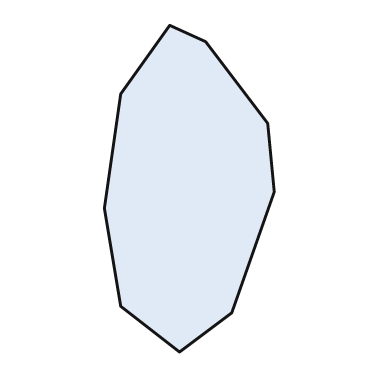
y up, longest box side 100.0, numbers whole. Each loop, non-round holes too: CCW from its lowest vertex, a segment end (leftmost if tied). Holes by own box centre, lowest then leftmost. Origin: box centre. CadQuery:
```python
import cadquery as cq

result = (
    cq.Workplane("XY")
    .moveTo(-3.0, -50.0)
    .lineTo(13.0, -38.0)
    .lineTo(26.0, -1.0)
    .lineTo(24.0, 20.0)
    .lineTo(5.0, 45.0)
    .lineTo(-6.0, 50.0)
    .lineTo(-21.0, 29.0)
    .lineTo(-26.0, -6.0)
    .lineTo(-21.0, -36.0)
    .close()
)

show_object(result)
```